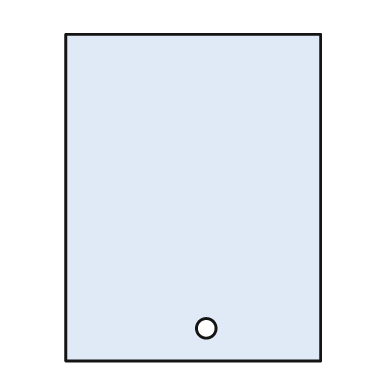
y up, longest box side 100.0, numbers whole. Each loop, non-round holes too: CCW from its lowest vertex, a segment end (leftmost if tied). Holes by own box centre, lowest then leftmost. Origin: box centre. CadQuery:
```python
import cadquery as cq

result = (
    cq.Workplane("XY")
    .moveTo(-39.0, -50.0)
    .lineTo(39.0, -50.0)
    .lineTo(39.0, 50.0)
    .lineTo(-39.0, 50.0)
    .close()
    .moveTo(4.0, -40.0)
    .circle(3.0)
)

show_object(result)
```